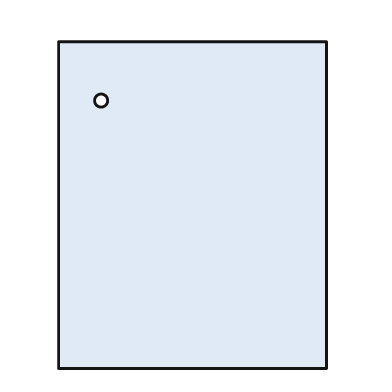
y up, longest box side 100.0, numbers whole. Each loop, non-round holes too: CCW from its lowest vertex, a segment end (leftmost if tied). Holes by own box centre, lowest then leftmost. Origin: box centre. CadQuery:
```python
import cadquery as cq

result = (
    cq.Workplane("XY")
    .moveTo(-41.0, -50.0)
    .lineTo(41.0, -50.0)
    .lineTo(41.0, 50.0)
    .lineTo(-41.0, 50.0)
    .close()
    .moveTo(-28.0, 32.0)
    .circle(2.0)
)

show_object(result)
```